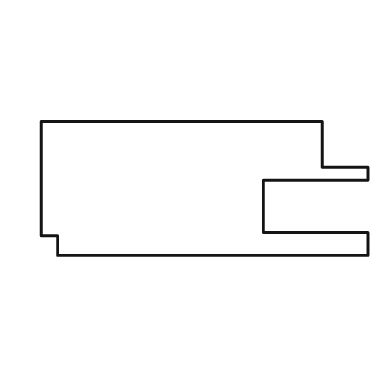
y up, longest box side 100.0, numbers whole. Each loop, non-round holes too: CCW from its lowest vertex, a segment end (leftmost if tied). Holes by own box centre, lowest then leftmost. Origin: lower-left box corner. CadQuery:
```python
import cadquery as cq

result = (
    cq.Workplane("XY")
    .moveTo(5.0, 0.0)
    .lineTo(100.0, 0.0)
    .lineTo(100.0, 7.0)
    .lineTo(68.0, 7.0)
    .lineTo(68.0, 23.0)
    .lineTo(100.0, 23.0)
    .lineTo(100.0, 27.0)
    .lineTo(86.0, 27.0)
    .lineTo(86.0, 41.0)
    .lineTo(0.0, 41.0)
    .lineTo(0.0, 6.0)
    .lineTo(5.0, 6.0)
    .close()
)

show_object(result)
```